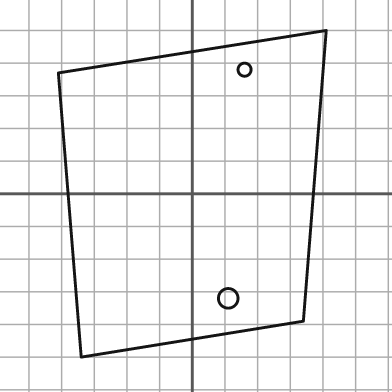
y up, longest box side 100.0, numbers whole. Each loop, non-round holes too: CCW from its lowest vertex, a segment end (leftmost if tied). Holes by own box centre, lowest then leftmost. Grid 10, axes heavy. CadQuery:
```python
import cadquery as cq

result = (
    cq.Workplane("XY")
    .moveTo(-34.0, -50.0)
    .lineTo(34.0, -39.0)
    .lineTo(41.0, 50.0)
    .lineTo(-41.0, 37.0)
    .close()
    .moveTo(11.0, -32.0)
    .circle(3.0)
    .moveTo(16.0, 38.0)
    .circle(2.0)
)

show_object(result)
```